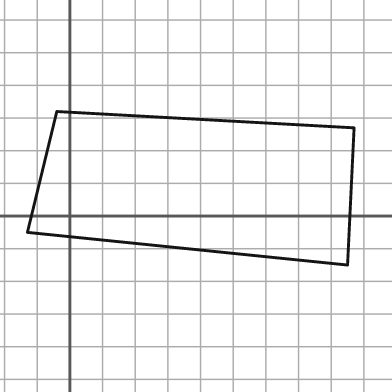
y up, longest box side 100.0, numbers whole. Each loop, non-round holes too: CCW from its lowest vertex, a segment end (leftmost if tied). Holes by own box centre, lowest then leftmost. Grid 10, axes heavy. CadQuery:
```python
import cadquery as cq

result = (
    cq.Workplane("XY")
    .moveTo(85.0, -15.0)
    .lineTo(87.0, 27.0)
    .lineTo(-4.0, 32.0)
    .lineTo(-13.0, -5.0)
    .close()
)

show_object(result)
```